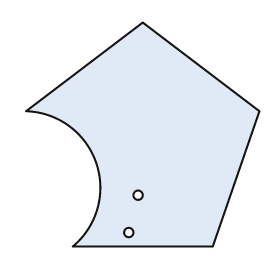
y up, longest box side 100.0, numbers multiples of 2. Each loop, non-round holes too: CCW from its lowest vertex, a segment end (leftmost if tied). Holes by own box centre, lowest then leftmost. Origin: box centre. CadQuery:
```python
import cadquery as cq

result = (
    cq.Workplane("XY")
    .moveTo(-30.0, -48.0)
    .lineTo(30.0, -48.0)
    .lineTo(50.0, 10.0)
    .lineTo(0.0, 48.0)
    .lineTo(-50.0, 10.0)
    .threePointArc((-20.0, -12.0), (-30.0, -48.0))
    .close()
    .moveTo(-6.0, -42.0)
    .circle(2.0)
    .moveTo(-2.0, -26.0)
    .circle(2.0)
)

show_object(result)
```